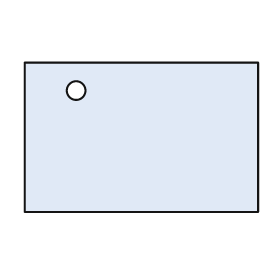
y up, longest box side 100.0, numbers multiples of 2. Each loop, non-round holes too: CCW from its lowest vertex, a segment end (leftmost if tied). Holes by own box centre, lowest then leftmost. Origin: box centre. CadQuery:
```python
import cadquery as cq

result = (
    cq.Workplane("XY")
    .moveTo(-50.0, -32.0)
    .lineTo(50.0, -32.0)
    .lineTo(50.0, 32.0)
    .lineTo(-50.0, 32.0)
    .close()
    .moveTo(-28.0, 20.0)
    .circle(4.0)
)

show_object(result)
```